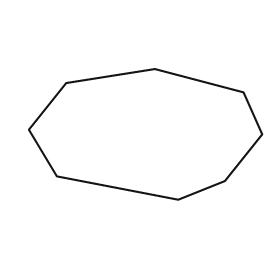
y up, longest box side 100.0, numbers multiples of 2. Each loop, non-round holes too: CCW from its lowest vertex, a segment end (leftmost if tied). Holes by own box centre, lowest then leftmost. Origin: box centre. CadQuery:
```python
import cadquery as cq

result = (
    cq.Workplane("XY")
    .moveTo(14.0, -28.0)
    .lineTo(34.0, -20.0)
    .lineTo(50.0, 0.0)
    .lineTo(42.0, 18.0)
    .lineTo(4.0, 28.0)
    .lineTo(-34.0, 22.0)
    .lineTo(-50.0, 2.0)
    .lineTo(-38.0, -18.0)
    .close()
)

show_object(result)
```